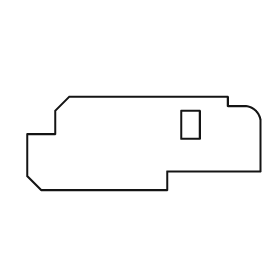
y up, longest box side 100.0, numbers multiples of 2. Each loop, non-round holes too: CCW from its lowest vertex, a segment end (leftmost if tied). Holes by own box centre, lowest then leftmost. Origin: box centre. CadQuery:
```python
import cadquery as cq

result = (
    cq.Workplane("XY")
    .moveTo(-44.0, -20.0)
    .lineTo(10.0, -20.0)
    .lineTo(10.0, -12.0)
    .lineTo(50.0, -12.0)
    .lineTo(50.0, 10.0)
    .threePointArc((48.0, 14.0), (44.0, 16.0))
    .lineTo(36.0, 16.0)
    .lineTo(36.0, 20.0)
    .lineTo(-32.0, 20.0)
    .lineTo(-38.0, 14.0)
    .lineTo(-38.0, 4.0)
    .lineTo(-50.0, 4.0)
    .lineTo(-50.0, -14.0)
    .close()
    .moveTo(16.0, 2.0)
    .lineTo(24.0, 2.0)
    .lineTo(24.0, 14.0)
    .lineTo(16.0, 14.0)
    .close()
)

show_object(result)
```